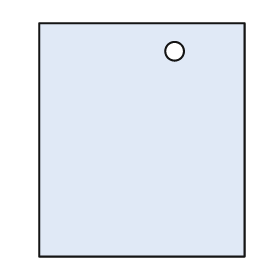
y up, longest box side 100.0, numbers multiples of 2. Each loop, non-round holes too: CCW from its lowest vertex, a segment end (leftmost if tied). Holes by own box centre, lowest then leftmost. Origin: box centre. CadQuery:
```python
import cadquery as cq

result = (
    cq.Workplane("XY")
    .moveTo(-44.0, -50.0)
    .lineTo(44.0, -50.0)
    .lineTo(44.0, 50.0)
    .lineTo(-44.0, 50.0)
    .close()
    .moveTo(14.0, 38.0)
    .circle(4.0)
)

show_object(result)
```